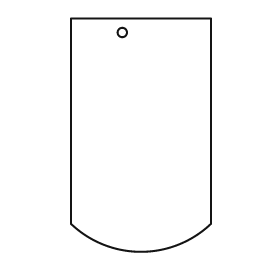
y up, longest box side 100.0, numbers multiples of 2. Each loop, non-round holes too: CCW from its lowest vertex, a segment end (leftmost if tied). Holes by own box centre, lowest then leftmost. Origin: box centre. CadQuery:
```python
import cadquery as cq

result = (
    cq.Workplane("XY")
    .moveTo(-30.0, -38.0)
    .threePointArc((0.0, -50.0), (30.0, -38.0))
    .lineTo(30.0, 50.0)
    .lineTo(-30.0, 50.0)
    .close()
    .moveTo(-8.0, 44.0)
    .circle(2.0)
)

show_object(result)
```